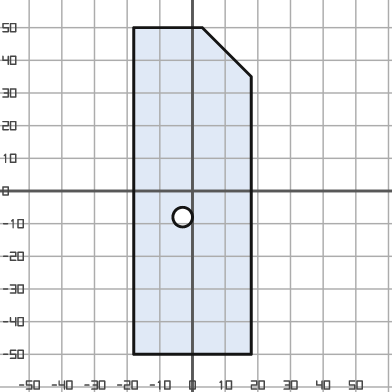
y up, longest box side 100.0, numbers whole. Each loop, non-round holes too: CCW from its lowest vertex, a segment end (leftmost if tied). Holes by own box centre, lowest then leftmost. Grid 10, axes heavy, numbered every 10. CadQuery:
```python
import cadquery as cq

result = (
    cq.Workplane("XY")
    .moveTo(-18.0, -50.0)
    .lineTo(18.0, -50.0)
    .lineTo(18.0, 35.0)
    .lineTo(3.0, 50.0)
    .lineTo(-18.0, 50.0)
    .close()
    .moveTo(-3.0, -8.0)
    .circle(3.0)
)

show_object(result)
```